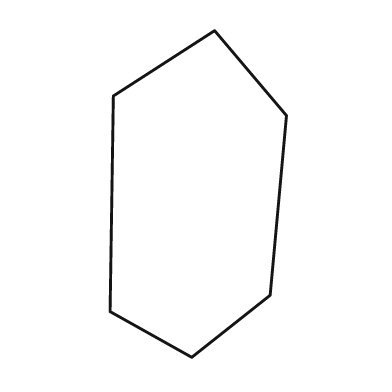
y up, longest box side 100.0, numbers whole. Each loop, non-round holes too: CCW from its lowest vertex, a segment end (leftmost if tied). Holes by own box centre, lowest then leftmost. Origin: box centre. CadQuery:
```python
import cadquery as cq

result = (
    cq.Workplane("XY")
    .moveTo(-2.0, -50.0)
    .lineTo(22.0, -31.0)
    .lineTo(27.0, 24.0)
    .lineTo(5.0, 50.0)
    .lineTo(-26.0, 30.0)
    .lineTo(-27.0, -36.0)
    .close()
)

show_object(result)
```